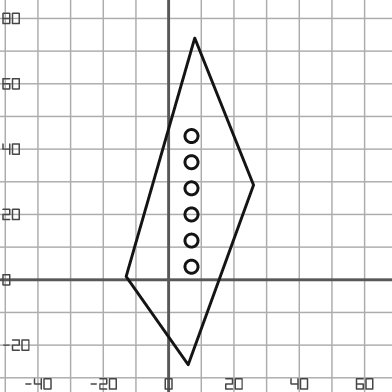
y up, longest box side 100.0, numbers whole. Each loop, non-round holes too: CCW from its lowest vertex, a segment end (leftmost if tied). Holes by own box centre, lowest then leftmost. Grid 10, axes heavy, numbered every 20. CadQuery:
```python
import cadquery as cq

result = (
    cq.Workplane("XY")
    .moveTo(6.0, -26.0)
    .lineTo(26.0, 29.0)
    .lineTo(8.0, 74.0)
    .lineTo(-13.0, 1.0)
    .close()
    .moveTo(7.0, 4.0)
    .circle(2.0)
    .moveTo(7.0, 12.0)
    .circle(2.0)
    .moveTo(7.0, 20.0)
    .circle(2.0)
    .moveTo(7.0, 28.0)
    .circle(2.0)
    .moveTo(7.0, 36.0)
    .circle(2.0)
    .moveTo(7.0, 44.0)
    .circle(2.0)
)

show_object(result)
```